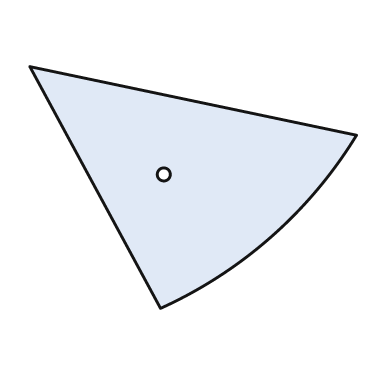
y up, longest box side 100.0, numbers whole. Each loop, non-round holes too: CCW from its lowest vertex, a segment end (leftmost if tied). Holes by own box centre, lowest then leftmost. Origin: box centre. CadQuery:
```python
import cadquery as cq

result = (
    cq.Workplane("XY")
    .moveTo(-10.0, -37.0)
    .threePointArc((24.0, -15.0), (50.0, 16.0))
    .lineTo(-50.0, 37.0)
    .close()
    .moveTo(-9.0, 4.0)
    .circle(2.0)
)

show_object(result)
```